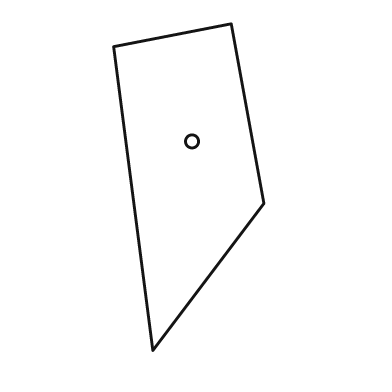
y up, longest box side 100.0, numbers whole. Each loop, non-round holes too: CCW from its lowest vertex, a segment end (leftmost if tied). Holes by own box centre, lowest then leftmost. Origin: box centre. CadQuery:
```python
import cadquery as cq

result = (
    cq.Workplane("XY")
    .moveTo(-11.0, -50.0)
    .lineTo(23.0, -5.0)
    .lineTo(13.0, 50.0)
    .lineTo(-23.0, 43.0)
    .close()
    .moveTo(1.0, 14.0)
    .circle(2.0)
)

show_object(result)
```